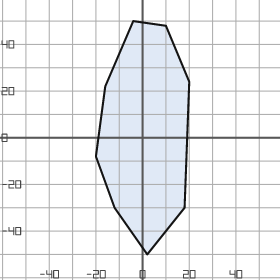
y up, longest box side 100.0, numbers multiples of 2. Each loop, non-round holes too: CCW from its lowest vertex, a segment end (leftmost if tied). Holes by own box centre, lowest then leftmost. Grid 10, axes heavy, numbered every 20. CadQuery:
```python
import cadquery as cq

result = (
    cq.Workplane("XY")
    .moveTo(2.0, -50.0)
    .lineTo(18.0, -30.0)
    .lineTo(20.0, 24.0)
    .lineTo(10.0, 48.0)
    .lineTo(-4.0, 50.0)
    .lineTo(-16.0, 22.0)
    .lineTo(-20.0, -8.0)
    .lineTo(-12.0, -30.0)
    .close()
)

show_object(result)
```